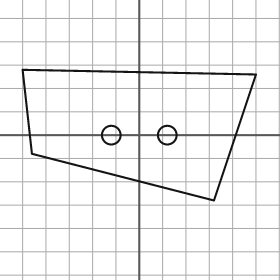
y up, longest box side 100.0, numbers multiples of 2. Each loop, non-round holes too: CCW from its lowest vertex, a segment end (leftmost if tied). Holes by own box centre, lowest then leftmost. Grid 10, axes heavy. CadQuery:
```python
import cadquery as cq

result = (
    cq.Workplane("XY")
    .moveTo(32.0, -28.0)
    .lineTo(50.0, 26.0)
    .lineTo(-50.0, 28.0)
    .lineTo(-46.0, -8.0)
    .close()
    .moveTo(-12.0, 0.0)
    .circle(4.0)
    .moveTo(12.0, 0.0)
    .circle(4.0)
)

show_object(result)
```